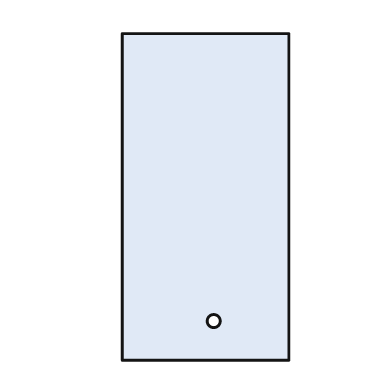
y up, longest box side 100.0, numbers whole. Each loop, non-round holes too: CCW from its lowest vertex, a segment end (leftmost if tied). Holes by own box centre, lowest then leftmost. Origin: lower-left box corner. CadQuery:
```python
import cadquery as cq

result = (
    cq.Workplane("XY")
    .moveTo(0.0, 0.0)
    .lineTo(51.0, 0.0)
    .lineTo(51.0, 100.0)
    .lineTo(0.0, 100.0)
    .close()
    .moveTo(28.0, 12.0)
    .circle(2.0)
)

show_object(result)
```